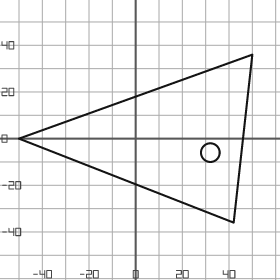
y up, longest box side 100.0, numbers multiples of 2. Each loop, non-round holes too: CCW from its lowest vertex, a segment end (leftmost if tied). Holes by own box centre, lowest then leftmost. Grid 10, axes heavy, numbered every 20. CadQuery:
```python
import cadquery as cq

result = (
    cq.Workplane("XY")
    .moveTo(42.0, -36.0)
    .lineTo(50.0, 36.0)
    .lineTo(-50.0, 0.0)
    .close()
    .moveTo(32.0, -6.0)
    .circle(4.0)
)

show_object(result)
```